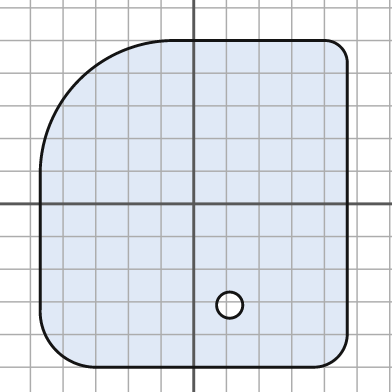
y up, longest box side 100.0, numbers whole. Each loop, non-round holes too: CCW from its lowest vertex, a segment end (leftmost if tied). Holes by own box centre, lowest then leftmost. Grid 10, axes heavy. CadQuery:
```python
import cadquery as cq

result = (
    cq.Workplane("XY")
    .moveTo(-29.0, -50.0)
    .lineTo(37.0, -50.0)
    .threePointArc((44.0, -47.0), (47.0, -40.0))
    .lineTo(47.0, 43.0)
    .threePointArc((45.0, 48.0), (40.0, 50.0))
    .lineTo(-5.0, 50.0)
    .threePointArc((-35.0, 38.0), (-47.0, 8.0))
    .lineTo(-47.0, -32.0)
    .threePointArc((-42.0, -45.0), (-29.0, -50.0))
    .close()
    .moveTo(11.0, -31.0)
    .circle(4.0)
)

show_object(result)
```